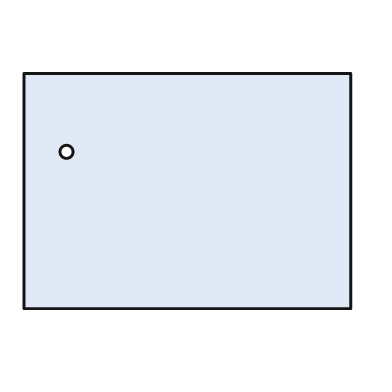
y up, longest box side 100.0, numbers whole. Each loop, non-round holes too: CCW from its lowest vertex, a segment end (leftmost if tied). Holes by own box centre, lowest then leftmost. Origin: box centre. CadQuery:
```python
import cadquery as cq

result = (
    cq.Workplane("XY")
    .moveTo(-50.0, -36.0)
    .lineTo(50.0, -36.0)
    .lineTo(50.0, 36.0)
    .lineTo(-50.0, 36.0)
    .close()
    .moveTo(-37.0, 12.0)
    .circle(2.0)
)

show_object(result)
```